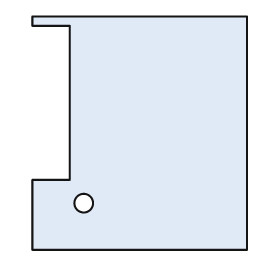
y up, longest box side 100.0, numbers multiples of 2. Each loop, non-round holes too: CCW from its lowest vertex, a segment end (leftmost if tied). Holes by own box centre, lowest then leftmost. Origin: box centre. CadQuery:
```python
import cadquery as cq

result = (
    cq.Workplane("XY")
    .moveTo(-46.0, -50.0)
    .lineTo(46.0, -50.0)
    .lineTo(46.0, 50.0)
    .lineTo(-46.0, 50.0)
    .lineTo(-46.0, 46.0)
    .lineTo(-30.0, 46.0)
    .lineTo(-30.0, -20.0)
    .lineTo(-46.0, -20.0)
    .close()
    .moveTo(-24.0, -30.0)
    .circle(4.0)
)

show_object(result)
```